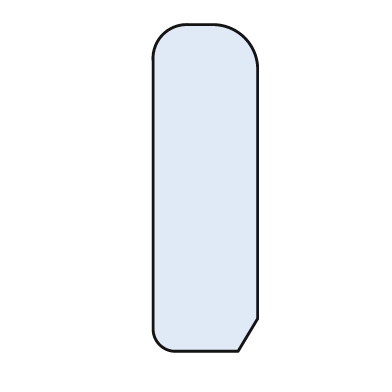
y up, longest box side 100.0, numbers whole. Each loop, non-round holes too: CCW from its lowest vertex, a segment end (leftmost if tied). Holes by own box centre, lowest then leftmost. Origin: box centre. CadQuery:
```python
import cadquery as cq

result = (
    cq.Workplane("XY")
    .moveTo(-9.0, -50.0)
    .lineTo(10.0, -50.0)
    .lineTo(16.0, -40.0)
    .lineTo(16.0, 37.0)
    .threePointArc((12.0, 46.0), (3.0, 50.0))
    .lineTo(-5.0, 50.0)
    .threePointArc((-13.0, 47.0), (-16.0, 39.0))
    .lineTo(-16.0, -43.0)
    .threePointArc((-14.0, -48.0), (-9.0, -50.0))
    .close()
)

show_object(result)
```